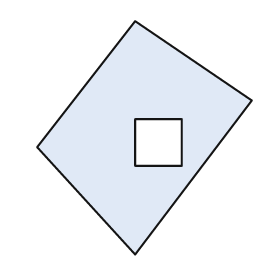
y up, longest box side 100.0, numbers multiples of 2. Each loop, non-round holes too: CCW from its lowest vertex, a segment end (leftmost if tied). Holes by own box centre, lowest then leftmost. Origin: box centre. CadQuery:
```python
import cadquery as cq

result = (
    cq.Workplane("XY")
    .moveTo(-4.0, -50.0)
    .lineTo(46.0, 16.0)
    .lineTo(-4.0, 50.0)
    .lineTo(-46.0, -4.0)
    .close()
    .moveTo(-4.0, -12.0)
    .lineTo(16.0, -12.0)
    .lineTo(16.0, 8.0)
    .lineTo(-4.0, 8.0)
    .close()
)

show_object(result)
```